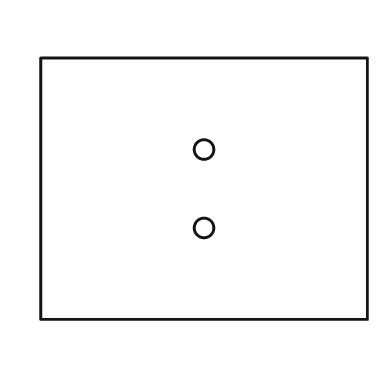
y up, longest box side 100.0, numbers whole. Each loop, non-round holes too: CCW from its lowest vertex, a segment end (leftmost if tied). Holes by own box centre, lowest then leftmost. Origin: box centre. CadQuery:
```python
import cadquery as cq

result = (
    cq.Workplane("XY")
    .moveTo(-50.0, -40.0)
    .lineTo(50.0, -40.0)
    .lineTo(50.0, 40.0)
    .lineTo(-50.0, 40.0)
    .close()
    .moveTo(0.0, -12.0)
    .circle(3.0)
    .moveTo(0.0, 12.0)
    .circle(3.0)
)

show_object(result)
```